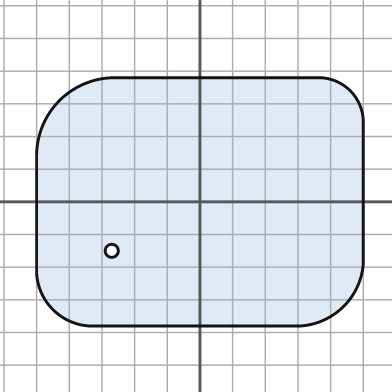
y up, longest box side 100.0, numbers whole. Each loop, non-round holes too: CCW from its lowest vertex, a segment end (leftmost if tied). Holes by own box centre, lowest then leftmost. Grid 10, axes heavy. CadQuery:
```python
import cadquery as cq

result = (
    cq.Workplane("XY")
    .moveTo(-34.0, -38.0)
    .lineTo(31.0, -38.0)
    .threePointArc((44.0, -32.0), (50.0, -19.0))
    .lineTo(50.0, 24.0)
    .threePointArc((46.0, 34.0), (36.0, 38.0))
    .lineTo(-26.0, 38.0)
    .threePointArc((-43.0, 31.0), (-50.0, 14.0))
    .lineTo(-50.0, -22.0)
    .threePointArc((-45.0, -33.0), (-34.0, -38.0))
    .close()
    .moveTo(-27.0, -15.0)
    .circle(2.0)
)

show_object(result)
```